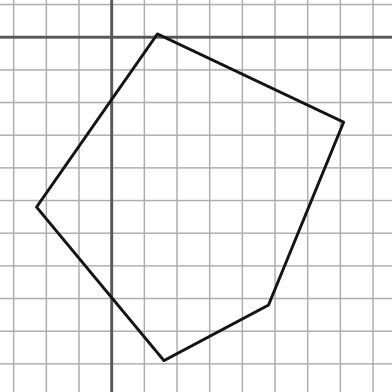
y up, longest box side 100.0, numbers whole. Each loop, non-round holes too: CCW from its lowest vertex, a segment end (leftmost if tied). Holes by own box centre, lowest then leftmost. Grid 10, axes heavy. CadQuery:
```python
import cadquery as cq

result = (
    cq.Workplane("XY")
    .moveTo(16.0, -99.0)
    .lineTo(48.0, -82.0)
    .lineTo(71.0, -26.0)
    .lineTo(14.0, 1.0)
    .lineTo(-23.0, -52.0)
    .close()
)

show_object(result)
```